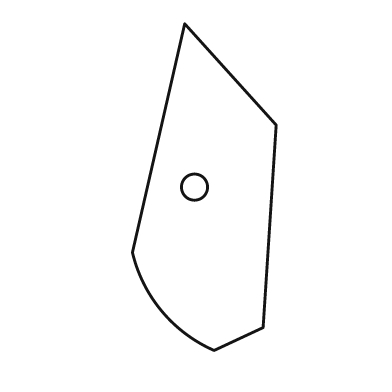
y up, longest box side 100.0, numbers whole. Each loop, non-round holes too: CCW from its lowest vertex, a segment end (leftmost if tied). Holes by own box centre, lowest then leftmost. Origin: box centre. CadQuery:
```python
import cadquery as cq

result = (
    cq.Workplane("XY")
    .moveTo(3.0, -50.0)
    .lineTo(18.0, -43.0)
    .lineTo(22.0, 19.0)
    .lineTo(-6.0, 50.0)
    .lineTo(-22.0, -20.0)
    .threePointArc((-13.0, -38.0), (3.0, -50.0))
    .close()
    .moveTo(-3.0, 0.0)
    .circle(4.0)
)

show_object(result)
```